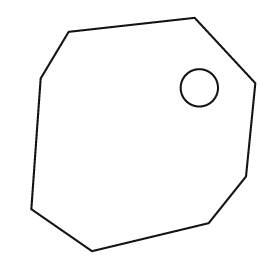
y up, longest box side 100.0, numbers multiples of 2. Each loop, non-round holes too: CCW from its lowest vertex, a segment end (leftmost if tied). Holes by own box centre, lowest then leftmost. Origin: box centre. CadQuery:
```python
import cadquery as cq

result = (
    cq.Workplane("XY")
    .moveTo(-22.0, -50.0)
    .lineTo(28.0, -38.0)
    .lineTo(44.0, -18.0)
    .lineTo(48.0, 22.0)
    .lineTo(22.0, 50.0)
    .lineTo(-32.0, 44.0)
    .lineTo(-44.0, 24.0)
    .lineTo(-48.0, -32.0)
    .close()
    .moveTo(24.0, 20.0)
    .circle(8.0)
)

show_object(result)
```